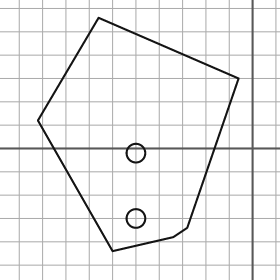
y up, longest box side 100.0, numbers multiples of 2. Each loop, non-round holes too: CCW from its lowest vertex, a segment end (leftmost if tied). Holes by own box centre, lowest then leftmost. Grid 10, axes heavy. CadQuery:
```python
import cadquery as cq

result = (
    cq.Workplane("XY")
    .moveTo(-60.0, -44.0)
    .lineTo(-34.0, -38.0)
    .lineTo(-28.0, -34.0)
    .lineTo(-6.0, 30.0)
    .lineTo(-66.0, 56.0)
    .lineTo(-92.0, 12.0)
    .close()
    .moveTo(-50.0, -30.0)
    .circle(4.0)
    .moveTo(-50.0, -2.0)
    .circle(4.0)
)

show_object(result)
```